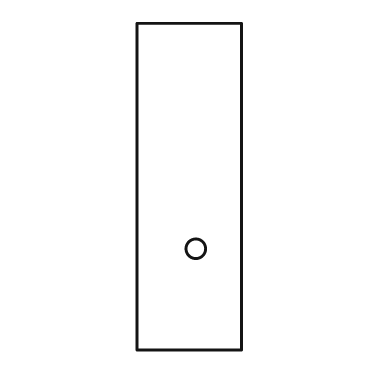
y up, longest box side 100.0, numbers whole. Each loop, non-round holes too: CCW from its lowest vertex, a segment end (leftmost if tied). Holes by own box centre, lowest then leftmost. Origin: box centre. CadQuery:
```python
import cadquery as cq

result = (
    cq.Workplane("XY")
    .moveTo(-16.0, -50.0)
    .lineTo(16.0, -50.0)
    .lineTo(16.0, 50.0)
    .lineTo(-16.0, 50.0)
    .close()
    .moveTo(2.0, -19.0)
    .circle(3.0)
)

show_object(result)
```